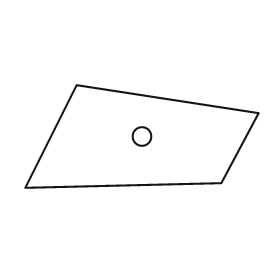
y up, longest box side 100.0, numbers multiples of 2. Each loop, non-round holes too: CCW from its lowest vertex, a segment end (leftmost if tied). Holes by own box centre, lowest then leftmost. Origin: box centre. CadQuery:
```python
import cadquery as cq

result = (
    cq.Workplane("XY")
    .moveTo(-50.0, -22.0)
    .lineTo(34.0, -20.0)
    .lineTo(50.0, 10.0)
    .lineTo(-28.0, 22.0)
    .close()
    .moveTo(0.0, 0.0)
    .circle(4.0)
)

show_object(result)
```